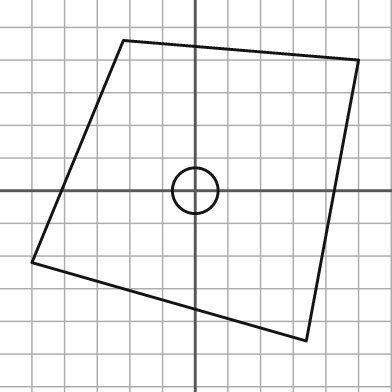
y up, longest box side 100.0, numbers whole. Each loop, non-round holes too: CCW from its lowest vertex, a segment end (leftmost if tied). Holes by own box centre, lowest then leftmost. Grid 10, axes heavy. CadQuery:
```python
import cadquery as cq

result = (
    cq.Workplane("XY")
    .moveTo(34.0, -46.0)
    .lineTo(50.0, 40.0)
    .lineTo(-22.0, 46.0)
    .lineTo(-50.0, -22.0)
    .close()
    .moveTo(0.0, 0.0)
    .circle(7.0)
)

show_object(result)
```